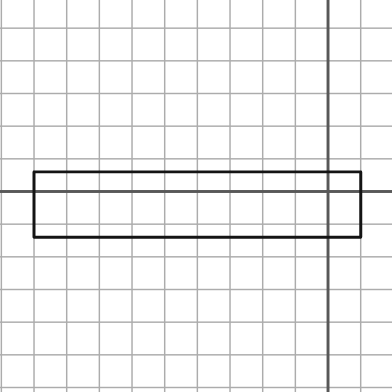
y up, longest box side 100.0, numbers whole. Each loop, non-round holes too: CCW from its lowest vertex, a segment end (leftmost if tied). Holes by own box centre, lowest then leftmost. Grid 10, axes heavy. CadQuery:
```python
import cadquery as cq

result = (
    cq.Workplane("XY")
    .moveTo(-90.0, -14.0)
    .lineTo(10.0, -14.0)
    .lineTo(10.0, 6.0)
    .lineTo(-90.0, 6.0)
    .close()
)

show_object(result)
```